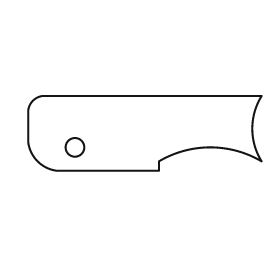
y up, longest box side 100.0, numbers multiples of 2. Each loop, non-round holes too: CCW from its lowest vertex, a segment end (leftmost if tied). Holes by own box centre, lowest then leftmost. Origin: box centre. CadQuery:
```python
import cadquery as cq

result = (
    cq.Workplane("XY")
    .moveTo(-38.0, -16.0)
    .lineTo(6.0, -16.0)
    .lineTo(6.0, -12.0)
    .threePointArc((28.0, -6.0), (50.0, -12.0))
    .threePointArc((46.0, 2.0), (50.0, 16.0))
    .lineTo(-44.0, 16.0)
    .threePointArc((-48.0, 14.0), (-50.0, 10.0))
    .lineTo(-50.0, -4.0)
    .threePointArc((-46.0, -12.0), (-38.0, -16.0))
    .close()
    .moveTo(-30.0, -6.0)
    .circle(4.0)
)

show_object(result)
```